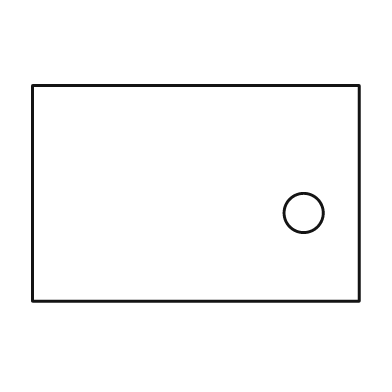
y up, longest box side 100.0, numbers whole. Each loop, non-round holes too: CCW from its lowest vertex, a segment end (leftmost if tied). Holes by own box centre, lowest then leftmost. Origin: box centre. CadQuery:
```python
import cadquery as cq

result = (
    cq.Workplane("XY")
    .moveTo(-50.0, -33.0)
    .lineTo(50.0, -33.0)
    .lineTo(50.0, 33.0)
    .lineTo(-50.0, 33.0)
    .close()
    .moveTo(33.0, -6.0)
    .circle(6.0)
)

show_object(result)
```